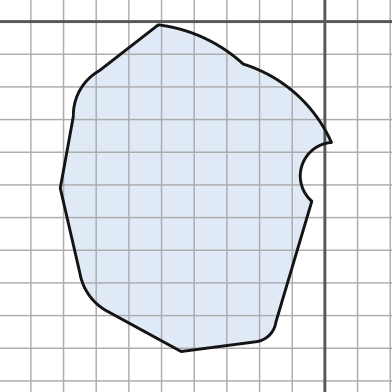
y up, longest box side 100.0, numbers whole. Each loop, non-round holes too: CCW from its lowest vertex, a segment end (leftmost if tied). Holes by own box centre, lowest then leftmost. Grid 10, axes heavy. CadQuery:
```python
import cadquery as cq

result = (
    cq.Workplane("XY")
    .moveTo(-44.0, -101.0)
    .lineTo(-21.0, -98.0)
    .threePointArc((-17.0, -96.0), (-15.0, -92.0))
    .lineTo(-4.0, -55.0)
    .threePointArc((-7.0, -44.0), (2.0, -37.0))
    .threePointArc((-9.0, -22.0), (-25.0, -13.0))
    .threePointArc((-37.0, -5.0), (-51.0, -1.0))
    .lineTo(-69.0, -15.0)
    .threePointArc((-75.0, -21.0), (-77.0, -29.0))
    .lineTo(-81.0, -51.0)
    .lineTo(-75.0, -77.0)
    .threePointArc((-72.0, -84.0), (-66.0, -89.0))
    .close()
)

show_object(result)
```